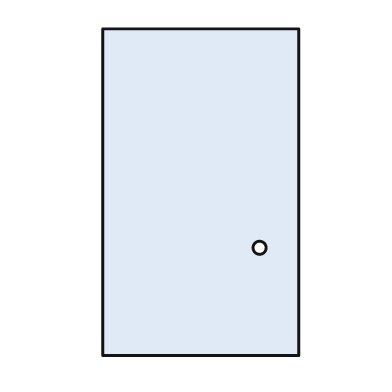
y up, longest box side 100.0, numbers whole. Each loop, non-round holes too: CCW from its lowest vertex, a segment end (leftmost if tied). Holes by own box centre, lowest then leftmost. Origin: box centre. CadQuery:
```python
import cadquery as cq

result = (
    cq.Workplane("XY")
    .moveTo(-30.0, -50.0)
    .lineTo(30.0, -50.0)
    .lineTo(30.0, 50.0)
    .lineTo(-30.0, 50.0)
    .close()
    .moveTo(18.0, -17.0)
    .circle(2.0)
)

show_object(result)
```